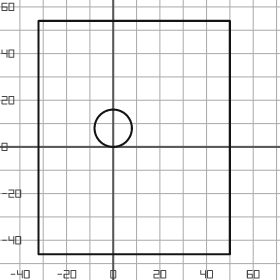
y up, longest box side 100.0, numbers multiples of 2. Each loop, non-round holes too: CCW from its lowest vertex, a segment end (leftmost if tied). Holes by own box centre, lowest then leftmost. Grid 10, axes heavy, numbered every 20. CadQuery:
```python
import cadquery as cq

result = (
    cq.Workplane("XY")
    .moveTo(-32.0, -46.0)
    .lineTo(50.0, -46.0)
    .lineTo(50.0, 54.0)
    .lineTo(-32.0, 54.0)
    .close()
    .moveTo(0.0, 8.0)
    .circle(8.0)
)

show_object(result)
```